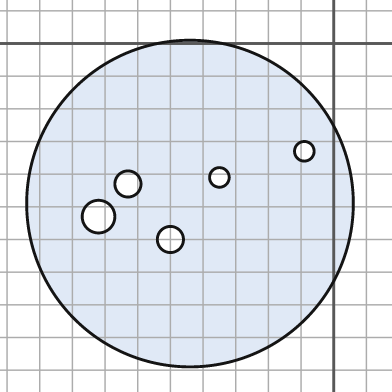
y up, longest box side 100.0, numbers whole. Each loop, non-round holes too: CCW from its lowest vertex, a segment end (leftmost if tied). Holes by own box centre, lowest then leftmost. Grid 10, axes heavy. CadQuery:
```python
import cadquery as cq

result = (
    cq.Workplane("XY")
    .moveTo(-44.0, -49.0)
    .circle(50.0)
    .moveTo(-50.0, -60.0)
    .circle(4.0)
    .moveTo(-72.0, -53.0)
    .circle(5.0)
    .moveTo(-63.0, -43.0)
    .circle(4.0)
    .moveTo(-35.0, -41.0)
    .circle(3.0)
    .moveTo(-9.0, -33.0)
    .circle(3.0)
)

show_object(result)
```